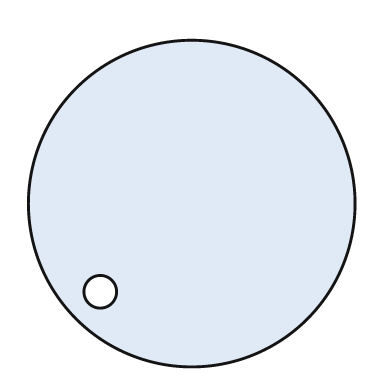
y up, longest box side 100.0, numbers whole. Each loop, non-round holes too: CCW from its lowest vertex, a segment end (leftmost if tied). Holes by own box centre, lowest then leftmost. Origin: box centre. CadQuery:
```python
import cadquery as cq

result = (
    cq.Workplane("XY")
    .moveTo(0.0, 0.0)
    .circle(50.0)
    .moveTo(-28.0, -27.0)
    .circle(5.0)
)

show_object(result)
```